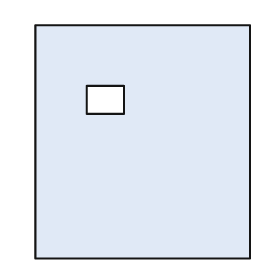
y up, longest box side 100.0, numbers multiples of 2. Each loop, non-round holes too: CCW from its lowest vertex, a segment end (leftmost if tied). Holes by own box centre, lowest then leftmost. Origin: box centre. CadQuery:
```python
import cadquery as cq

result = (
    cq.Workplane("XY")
    .moveTo(-46.0, -50.0)
    .lineTo(46.0, -50.0)
    .lineTo(46.0, 50.0)
    .lineTo(-46.0, 50.0)
    .close()
    .moveTo(-24.0, 12.0)
    .lineTo(-8.0, 12.0)
    .lineTo(-8.0, 24.0)
    .lineTo(-24.0, 24.0)
    .close()
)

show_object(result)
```